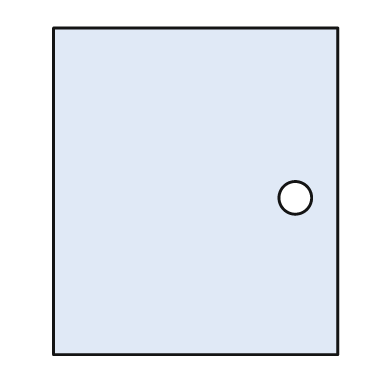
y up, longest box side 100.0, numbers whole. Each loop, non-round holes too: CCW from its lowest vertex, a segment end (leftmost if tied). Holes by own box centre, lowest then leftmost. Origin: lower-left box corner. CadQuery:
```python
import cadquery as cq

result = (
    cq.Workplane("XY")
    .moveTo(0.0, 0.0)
    .lineTo(87.0, 0.0)
    .lineTo(87.0, 100.0)
    .lineTo(0.0, 100.0)
    .close()
    .moveTo(74.0, 48.0)
    .circle(5.0)
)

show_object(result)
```